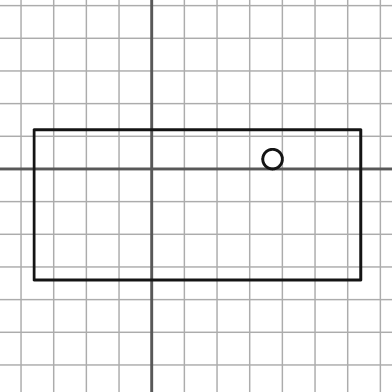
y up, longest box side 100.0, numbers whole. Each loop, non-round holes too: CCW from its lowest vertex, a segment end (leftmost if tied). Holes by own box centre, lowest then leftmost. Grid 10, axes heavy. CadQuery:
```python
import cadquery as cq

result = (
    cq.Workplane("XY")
    .moveTo(-36.0, -34.0)
    .lineTo(64.0, -34.0)
    .lineTo(64.0, 12.0)
    .lineTo(-36.0, 12.0)
    .close()
    .moveTo(37.0, 3.0)
    .circle(3.0)
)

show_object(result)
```